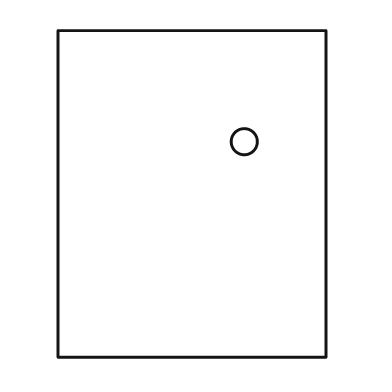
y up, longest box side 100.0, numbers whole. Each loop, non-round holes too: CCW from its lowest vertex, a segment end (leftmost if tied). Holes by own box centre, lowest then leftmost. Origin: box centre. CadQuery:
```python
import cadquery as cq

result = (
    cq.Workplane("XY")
    .moveTo(-41.0, -50.0)
    .lineTo(41.0, -50.0)
    .lineTo(41.0, 50.0)
    .lineTo(-41.0, 50.0)
    .close()
    .moveTo(16.0, 16.0)
    .circle(4.0)
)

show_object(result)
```